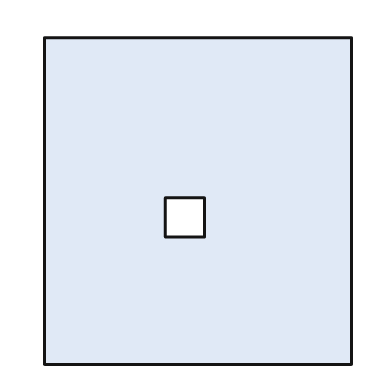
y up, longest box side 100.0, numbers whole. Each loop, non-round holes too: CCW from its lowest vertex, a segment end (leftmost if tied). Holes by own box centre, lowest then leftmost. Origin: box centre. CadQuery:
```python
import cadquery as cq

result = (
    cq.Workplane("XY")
    .moveTo(-47.0, -50.0)
    .lineTo(47.0, -50.0)
    .lineTo(47.0, 50.0)
    .lineTo(-47.0, 50.0)
    .close()
    .moveTo(-10.0, -11.0)
    .lineTo(2.0, -11.0)
    .lineTo(2.0, 1.0)
    .lineTo(-10.0, 1.0)
    .close()
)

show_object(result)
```